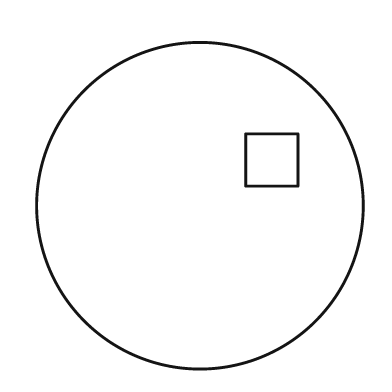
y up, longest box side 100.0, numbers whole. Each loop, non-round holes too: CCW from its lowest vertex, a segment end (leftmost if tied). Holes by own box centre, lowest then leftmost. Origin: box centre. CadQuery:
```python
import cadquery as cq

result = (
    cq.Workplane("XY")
    .moveTo(0.0, 0.0)
    .circle(50.0)
    .moveTo(14.0, 6.0)
    .lineTo(30.0, 6.0)
    .lineTo(30.0, 22.0)
    .lineTo(14.0, 22.0)
    .close()
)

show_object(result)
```